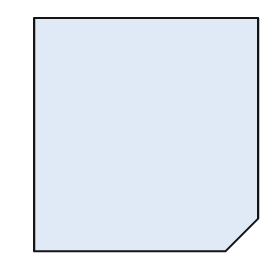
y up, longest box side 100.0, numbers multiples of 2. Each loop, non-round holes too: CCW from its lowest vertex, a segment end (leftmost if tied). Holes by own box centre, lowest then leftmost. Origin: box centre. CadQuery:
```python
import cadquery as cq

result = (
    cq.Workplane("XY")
    .moveTo(-48.0, -50.0)
    .lineTo(34.0, -50.0)
    .lineTo(48.0, -36.0)
    .lineTo(48.0, 50.0)
    .lineTo(-48.0, 50.0)
    .close()
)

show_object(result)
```